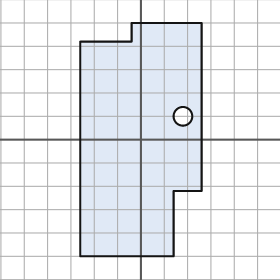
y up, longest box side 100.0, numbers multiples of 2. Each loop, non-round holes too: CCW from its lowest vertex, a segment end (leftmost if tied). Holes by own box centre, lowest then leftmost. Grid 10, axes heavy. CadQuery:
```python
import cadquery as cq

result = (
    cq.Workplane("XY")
    .moveTo(-26.0, -50.0)
    .lineTo(14.0, -50.0)
    .lineTo(14.0, -22.0)
    .lineTo(26.0, -22.0)
    .lineTo(26.0, 50.0)
    .lineTo(-4.0, 50.0)
    .lineTo(-4.0, 42.0)
    .lineTo(-26.0, 42.0)
    .close()
    .moveTo(18.0, 10.0)
    .circle(4.0)
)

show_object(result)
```